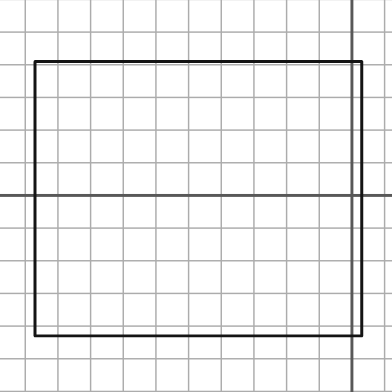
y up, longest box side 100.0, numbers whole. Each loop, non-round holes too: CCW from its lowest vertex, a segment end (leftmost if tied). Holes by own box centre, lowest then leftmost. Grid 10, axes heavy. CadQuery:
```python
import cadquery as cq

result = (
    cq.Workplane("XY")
    .moveTo(-97.0, -43.0)
    .lineTo(3.0, -43.0)
    .lineTo(3.0, 41.0)
    .lineTo(-97.0, 41.0)
    .close()
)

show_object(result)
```